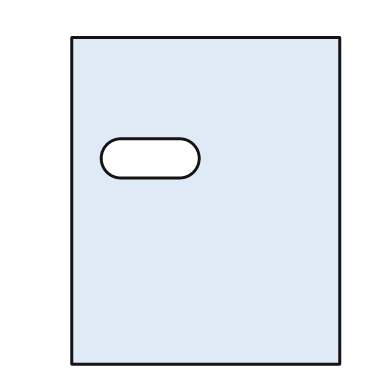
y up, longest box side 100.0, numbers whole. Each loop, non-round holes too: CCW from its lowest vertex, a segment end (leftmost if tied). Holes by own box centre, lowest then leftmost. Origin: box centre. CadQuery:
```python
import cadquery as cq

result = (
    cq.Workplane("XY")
    .moveTo(-41.0, -50.0)
    .lineTo(41.0, -50.0)
    .lineTo(41.0, 50.0)
    .lineTo(-41.0, 50.0)
    .close()
    .moveTo(-26.0, 7.0)
    .lineTo(-8.0, 7.0)
    .threePointArc((-2.0, 13.0), (-8.0, 19.0))
    .lineTo(-26.0, 19.0)
    .threePointArc((-32.0, 13.0), (-26.0, 7.0))
    .close()
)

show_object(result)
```